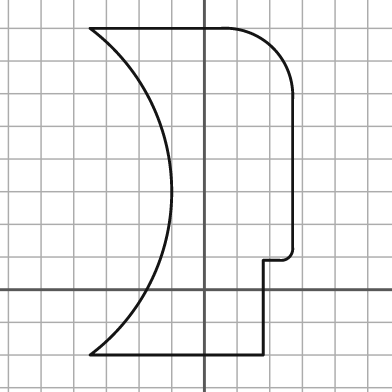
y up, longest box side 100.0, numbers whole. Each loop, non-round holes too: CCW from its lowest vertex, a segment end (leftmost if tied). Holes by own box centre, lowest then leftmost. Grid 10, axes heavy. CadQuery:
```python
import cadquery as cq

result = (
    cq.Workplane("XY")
    .moveTo(-35.0, -20.0)
    .lineTo(18.0, -20.0)
    .lineTo(18.0, 9.0)
    .lineTo(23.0, 9.0)
    .threePointArc((26.0, 10.0), (27.0, 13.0))
    .lineTo(27.0, 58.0)
    .threePointArc((21.0, 74.0), (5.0, 80.0))
    .lineTo(-35.0, 80.0)
    .threePointArc((-10.0, 30.0), (-35.0, -20.0))
    .close()
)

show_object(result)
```